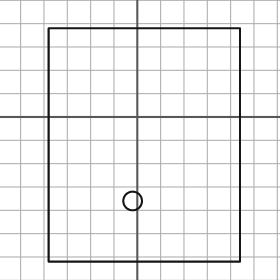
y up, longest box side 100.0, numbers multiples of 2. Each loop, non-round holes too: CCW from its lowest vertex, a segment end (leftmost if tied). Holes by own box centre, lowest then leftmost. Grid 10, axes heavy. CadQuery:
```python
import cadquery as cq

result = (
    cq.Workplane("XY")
    .moveTo(-38.0, -62.0)
    .lineTo(44.0, -62.0)
    .lineTo(44.0, 38.0)
    .lineTo(-38.0, 38.0)
    .close()
    .moveTo(-2.0, -36.0)
    .circle(4.0)
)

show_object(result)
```